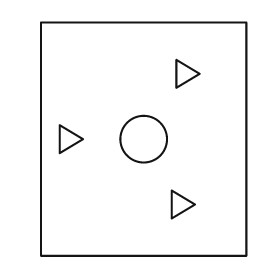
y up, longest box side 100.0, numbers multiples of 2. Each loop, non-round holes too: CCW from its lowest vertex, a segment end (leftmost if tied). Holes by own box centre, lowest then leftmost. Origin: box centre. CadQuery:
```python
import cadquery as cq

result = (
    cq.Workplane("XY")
    .moveTo(-44.0, -50.0)
    .lineTo(44.0, -50.0)
    .lineTo(44.0, 50.0)
    .lineTo(-44.0, 50.0)
    .close()
    .moveTo(12.0, -34.0)
    .lineTo(22.0, -28.0)
    .lineTo(12.0, -22.0)
    .close()
    .moveTo(-36.0, -6.0)
    .lineTo(-26.0, 0.0)
    .lineTo(-36.0, 6.0)
    .close()
    .moveTo(0.0, 0.0)
    .circle(10.0)
    .moveTo(14.0, 22.0)
    .lineTo(24.0, 28.0)
    .lineTo(14.0, 34.0)
    .close()
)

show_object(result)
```